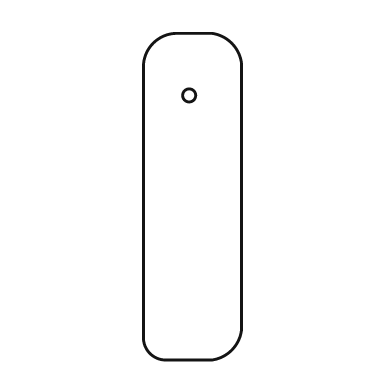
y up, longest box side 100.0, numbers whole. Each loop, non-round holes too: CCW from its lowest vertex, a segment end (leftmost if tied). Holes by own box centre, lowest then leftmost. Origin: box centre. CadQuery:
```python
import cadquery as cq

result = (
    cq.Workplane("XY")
    .moveTo(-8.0, -50.0)
    .lineTo(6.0, -50.0)
    .threePointArc((12.0, -47.0), (15.0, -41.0))
    .lineTo(15.0, 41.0)
    .threePointArc((12.0, 47.0), (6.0, 50.0))
    .lineTo(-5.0, 50.0)
    .threePointArc((-12.0, 47.0), (-15.0, 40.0))
    .lineTo(-15.0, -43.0)
    .threePointArc((-13.0, -48.0), (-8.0, -50.0))
    .close()
    .moveTo(-1.0, 31.0)
    .circle(2.0)
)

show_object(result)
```